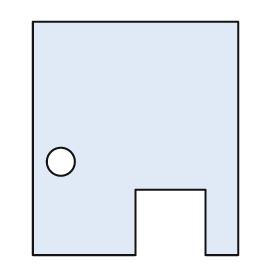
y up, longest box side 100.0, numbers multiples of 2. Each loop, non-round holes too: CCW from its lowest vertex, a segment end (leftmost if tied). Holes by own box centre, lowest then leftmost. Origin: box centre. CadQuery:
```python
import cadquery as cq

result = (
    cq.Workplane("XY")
    .moveTo(-44.0, -50.0)
    .lineTo(0.0, -50.0)
    .lineTo(0.0, -22.0)
    .lineTo(30.0, -22.0)
    .lineTo(30.0, -50.0)
    .lineTo(44.0, -50.0)
    .lineTo(44.0, 50.0)
    .lineTo(-44.0, 50.0)
    .close()
    .moveTo(-32.0, -10.0)
    .circle(6.0)
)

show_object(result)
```